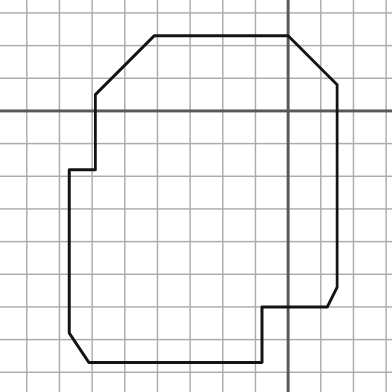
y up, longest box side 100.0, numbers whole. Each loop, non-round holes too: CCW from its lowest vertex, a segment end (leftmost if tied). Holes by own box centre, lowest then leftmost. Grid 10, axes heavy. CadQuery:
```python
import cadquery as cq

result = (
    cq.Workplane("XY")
    .moveTo(-61.0, -77.0)
    .lineTo(-8.0, -77.0)
    .lineTo(-8.0, -60.0)
    .lineTo(12.0, -60.0)
    .lineTo(15.0, -54.0)
    .lineTo(15.0, 8.0)
    .lineTo(0.0, 23.0)
    .lineTo(-41.0, 23.0)
    .lineTo(-59.0, 5.0)
    .lineTo(-59.0, -18.0)
    .lineTo(-67.0, -18.0)
    .lineTo(-67.0, -68.0)
    .close()
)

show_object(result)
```